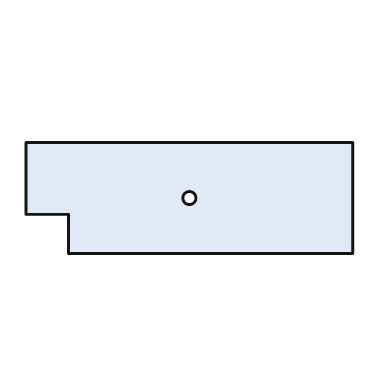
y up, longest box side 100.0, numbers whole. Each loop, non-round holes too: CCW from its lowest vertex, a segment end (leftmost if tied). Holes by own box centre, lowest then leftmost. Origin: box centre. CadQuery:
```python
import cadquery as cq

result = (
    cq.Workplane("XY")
    .moveTo(-37.0, -17.0)
    .lineTo(50.0, -17.0)
    .lineTo(50.0, 17.0)
    .lineTo(-50.0, 17.0)
    .lineTo(-50.0, -5.0)
    .lineTo(-37.0, -5.0)
    .close()
    .moveTo(0.0, 0.0)
    .circle(2.0)
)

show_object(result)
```